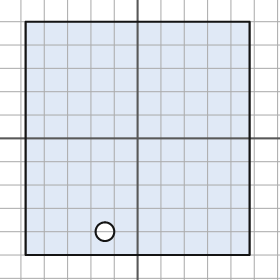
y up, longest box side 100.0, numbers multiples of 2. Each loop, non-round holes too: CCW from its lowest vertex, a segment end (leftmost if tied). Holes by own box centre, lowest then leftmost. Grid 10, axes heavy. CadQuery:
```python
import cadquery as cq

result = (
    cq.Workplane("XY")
    .moveTo(-48.0, -50.0)
    .lineTo(48.0, -50.0)
    .lineTo(48.0, 50.0)
    .lineTo(-48.0, 50.0)
    .close()
    .moveTo(-14.0, -40.0)
    .circle(4.0)
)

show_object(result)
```